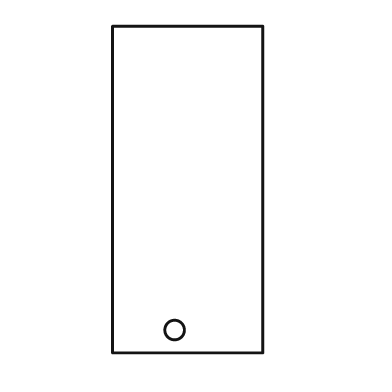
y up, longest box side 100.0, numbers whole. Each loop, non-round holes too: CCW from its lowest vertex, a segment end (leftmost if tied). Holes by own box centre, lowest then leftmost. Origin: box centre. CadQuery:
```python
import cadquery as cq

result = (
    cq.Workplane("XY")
    .moveTo(-23.0, -50.0)
    .lineTo(23.0, -50.0)
    .lineTo(23.0, 50.0)
    .lineTo(-23.0, 50.0)
    .close()
    .moveTo(-4.0, -43.0)
    .circle(3.0)
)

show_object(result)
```